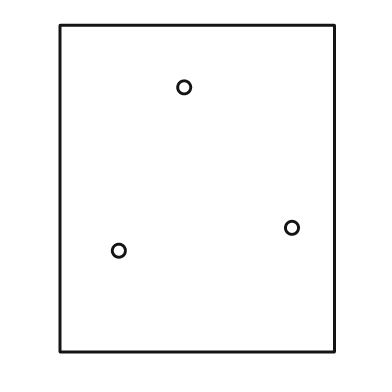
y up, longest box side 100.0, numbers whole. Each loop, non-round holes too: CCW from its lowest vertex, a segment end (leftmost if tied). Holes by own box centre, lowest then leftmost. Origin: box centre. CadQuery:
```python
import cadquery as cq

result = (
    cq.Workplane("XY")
    .moveTo(-42.0, -50.0)
    .lineTo(42.0, -50.0)
    .lineTo(42.0, 50.0)
    .lineTo(-42.0, 50.0)
    .close()
    .moveTo(-24.0, -19.0)
    .circle(2.0)
    .moveTo(29.0, -12.0)
    .circle(2.0)
    .moveTo(-4.0, 31.0)
    .circle(2.0)
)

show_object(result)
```